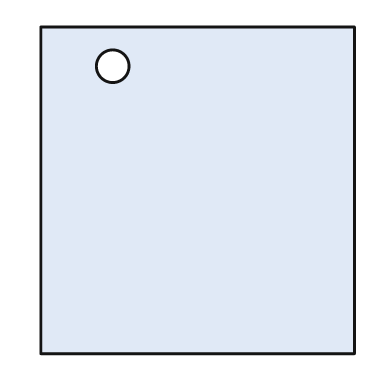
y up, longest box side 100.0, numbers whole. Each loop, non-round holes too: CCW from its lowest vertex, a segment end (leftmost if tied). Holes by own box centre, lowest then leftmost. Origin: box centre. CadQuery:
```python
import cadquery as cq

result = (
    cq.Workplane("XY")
    .moveTo(-48.0, -50.0)
    .lineTo(48.0, -50.0)
    .lineTo(48.0, 50.0)
    .lineTo(-48.0, 50.0)
    .close()
    .moveTo(-26.0, 38.0)
    .circle(5.0)
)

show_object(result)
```